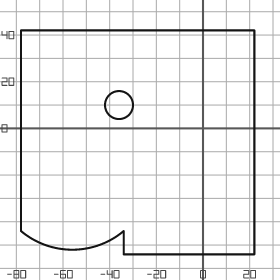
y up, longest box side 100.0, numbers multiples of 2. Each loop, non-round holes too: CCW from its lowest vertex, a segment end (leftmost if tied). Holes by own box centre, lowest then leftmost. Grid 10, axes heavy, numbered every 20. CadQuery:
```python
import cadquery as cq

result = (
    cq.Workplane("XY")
    .moveTo(-34.0, -54.0)
    .lineTo(22.0, -54.0)
    .lineTo(22.0, 42.0)
    .lineTo(-78.0, 42.0)
    .lineTo(-78.0, -44.0)
    .threePointArc((-56.0, -52.0), (-34.0, -44.0))
    .close()
    .moveTo(-36.0, 10.0)
    .circle(6.0)
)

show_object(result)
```